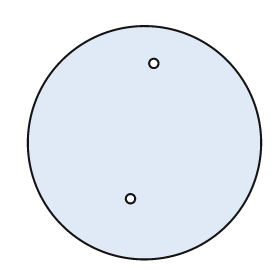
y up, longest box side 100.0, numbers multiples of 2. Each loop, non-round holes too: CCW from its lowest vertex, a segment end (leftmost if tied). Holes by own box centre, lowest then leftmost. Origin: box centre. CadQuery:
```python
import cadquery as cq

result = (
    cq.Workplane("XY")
    .moveTo(0.0, 0.0)
    .circle(50.0)
    .moveTo(-6.0, -24.0)
    .circle(2.0)
    .moveTo(4.0, 34.0)
    .circle(2.0)
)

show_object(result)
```